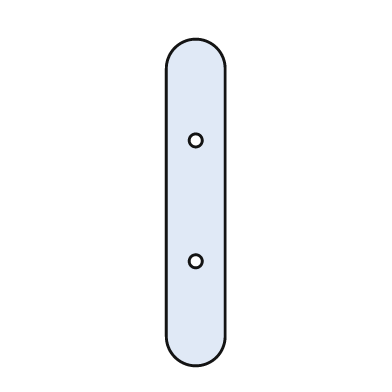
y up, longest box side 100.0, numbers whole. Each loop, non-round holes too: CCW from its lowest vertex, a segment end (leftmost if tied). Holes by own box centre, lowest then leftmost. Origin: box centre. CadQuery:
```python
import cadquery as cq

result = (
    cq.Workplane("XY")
    .moveTo(-9.0, -41.0)
    .threePointArc((0.0, -50.0), (9.0, -41.0))
    .lineTo(9.0, 41.0)
    .threePointArc((0.0, 50.0), (-9.0, 41.0))
    .close()
    .moveTo(0.0, -18.0)
    .circle(2.0)
    .moveTo(0.0, 19.0)
    .circle(2.0)
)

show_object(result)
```